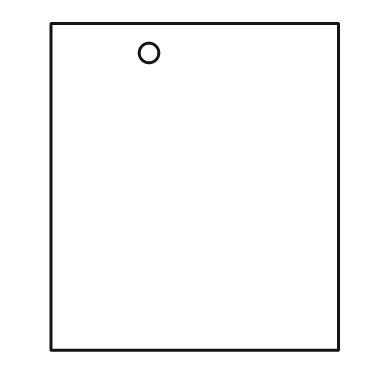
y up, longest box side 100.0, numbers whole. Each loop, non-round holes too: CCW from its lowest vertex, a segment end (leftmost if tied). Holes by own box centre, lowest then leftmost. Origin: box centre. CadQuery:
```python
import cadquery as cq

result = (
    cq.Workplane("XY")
    .moveTo(-44.0, -50.0)
    .lineTo(44.0, -50.0)
    .lineTo(44.0, 50.0)
    .lineTo(-44.0, 50.0)
    .close()
    .moveTo(-14.0, 41.0)
    .circle(3.0)
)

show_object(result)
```